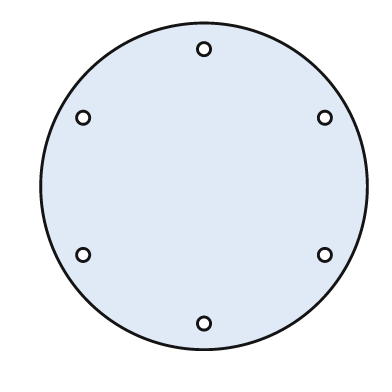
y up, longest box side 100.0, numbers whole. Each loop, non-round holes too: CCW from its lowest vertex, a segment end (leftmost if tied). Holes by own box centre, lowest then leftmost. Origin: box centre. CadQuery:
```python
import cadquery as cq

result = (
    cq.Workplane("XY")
    .moveTo(0.0, 0.0)
    .circle(50.0)
    .moveTo(0.0, -42.0)
    .circle(2.0)
    .moveTo(-37.0, -21.0)
    .circle(2.0)
    .moveTo(37.0, -21.0)
    .circle(2.0)
    .moveTo(-37.0, 21.0)
    .circle(2.0)
    .moveTo(37.0, 21.0)
    .circle(2.0)
    .moveTo(0.0, 42.0)
    .circle(2.0)
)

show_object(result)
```